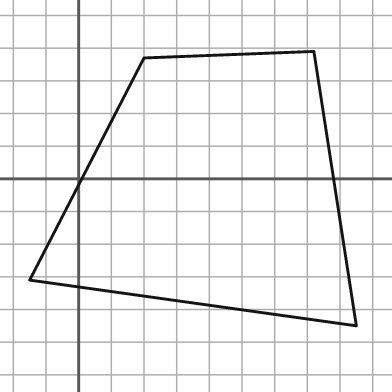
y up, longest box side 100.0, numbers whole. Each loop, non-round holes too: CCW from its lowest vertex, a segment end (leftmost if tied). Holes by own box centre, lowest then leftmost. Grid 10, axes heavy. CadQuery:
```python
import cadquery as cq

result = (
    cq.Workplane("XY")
    .moveTo(85.0, -45.0)
    .lineTo(72.0, 39.0)
    .lineTo(20.0, 37.0)
    .lineTo(-15.0, -31.0)
    .close()
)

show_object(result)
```